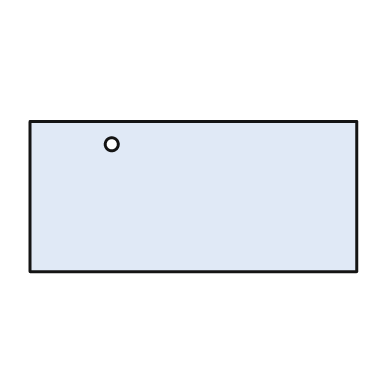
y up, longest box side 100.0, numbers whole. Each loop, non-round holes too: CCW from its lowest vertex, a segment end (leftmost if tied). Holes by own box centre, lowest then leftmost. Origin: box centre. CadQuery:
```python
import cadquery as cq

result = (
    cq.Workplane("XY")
    .moveTo(-50.0, -23.0)
    .lineTo(50.0, -23.0)
    .lineTo(50.0, 23.0)
    .lineTo(-50.0, 23.0)
    .close()
    .moveTo(-25.0, 16.0)
    .circle(2.0)
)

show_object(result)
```